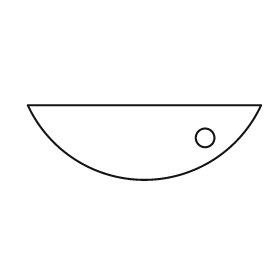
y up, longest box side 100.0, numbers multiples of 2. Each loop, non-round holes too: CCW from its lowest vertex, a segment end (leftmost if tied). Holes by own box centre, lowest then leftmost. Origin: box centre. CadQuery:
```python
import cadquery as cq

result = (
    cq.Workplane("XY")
    .moveTo(-50.0, 16.0)
    .threePointArc((0.0, -16.0), (50.0, 16.0))
    .close()
    .moveTo(26.0, 2.0)
    .circle(4.0)
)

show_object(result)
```